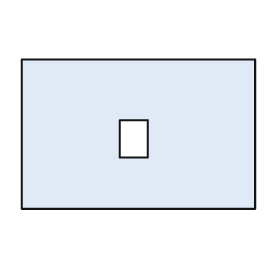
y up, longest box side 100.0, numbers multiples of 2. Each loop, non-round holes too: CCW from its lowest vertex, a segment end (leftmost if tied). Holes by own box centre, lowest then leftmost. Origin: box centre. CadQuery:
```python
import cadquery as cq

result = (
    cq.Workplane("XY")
    .moveTo(-50.0, -32.0)
    .lineTo(50.0, -32.0)
    .lineTo(50.0, 32.0)
    .lineTo(-50.0, 32.0)
    .close()
    .moveTo(-8.0, -10.0)
    .lineTo(4.0, -10.0)
    .lineTo(4.0, 6.0)
    .lineTo(-8.0, 6.0)
    .close()
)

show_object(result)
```